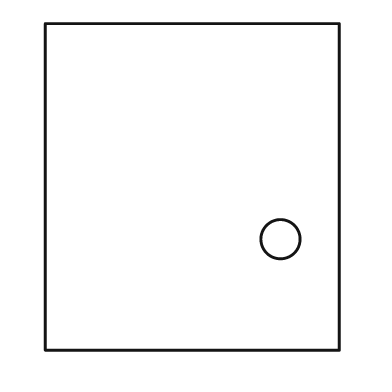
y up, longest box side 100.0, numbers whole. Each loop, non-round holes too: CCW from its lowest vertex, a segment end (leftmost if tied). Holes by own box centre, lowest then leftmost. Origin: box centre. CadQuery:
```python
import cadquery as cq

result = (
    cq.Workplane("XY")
    .moveTo(-45.0, -50.0)
    .lineTo(45.0, -50.0)
    .lineTo(45.0, 50.0)
    .lineTo(-45.0, 50.0)
    .close()
    .moveTo(27.0, -16.0)
    .circle(6.0)
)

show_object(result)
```